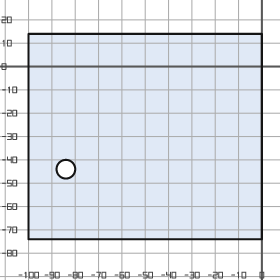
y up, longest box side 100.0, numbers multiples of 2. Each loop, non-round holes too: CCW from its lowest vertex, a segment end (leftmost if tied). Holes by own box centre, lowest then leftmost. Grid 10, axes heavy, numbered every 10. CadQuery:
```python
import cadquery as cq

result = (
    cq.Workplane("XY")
    .moveTo(-100.0, -74.0)
    .lineTo(0.0, -74.0)
    .lineTo(0.0, 14.0)
    .lineTo(-100.0, 14.0)
    .close()
    .moveTo(-84.0, -44.0)
    .circle(4.0)
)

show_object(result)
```